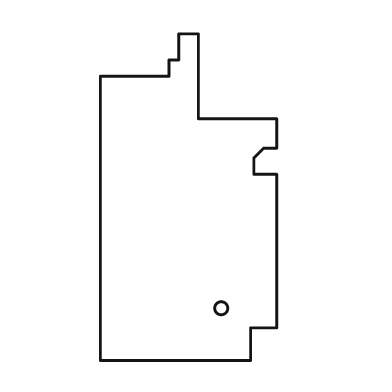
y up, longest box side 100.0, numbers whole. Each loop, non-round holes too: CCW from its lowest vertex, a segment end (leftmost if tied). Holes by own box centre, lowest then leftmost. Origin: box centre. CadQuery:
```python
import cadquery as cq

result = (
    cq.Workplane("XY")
    .moveTo(-27.0, -50.0)
    .lineTo(19.0, -50.0)
    .lineTo(19.0, -40.0)
    .lineTo(27.0, -40.0)
    .lineTo(27.0, 7.0)
    .lineTo(20.0, 7.0)
    .lineTo(20.0, 12.0)
    .lineTo(23.0, 15.0)
    .lineTo(27.0, 15.0)
    .lineTo(27.0, 24.0)
    .lineTo(3.0, 24.0)
    .lineTo(3.0, 50.0)
    .lineTo(-3.0, 50.0)
    .lineTo(-3.0, 42.0)
    .lineTo(-6.0, 42.0)
    .lineTo(-6.0, 37.0)
    .lineTo(-27.0, 37.0)
    .close()
    .moveTo(10.0, -34.0)
    .circle(2.0)
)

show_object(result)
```